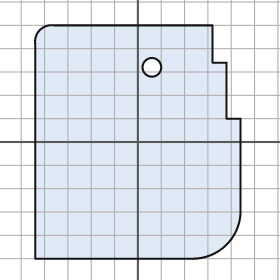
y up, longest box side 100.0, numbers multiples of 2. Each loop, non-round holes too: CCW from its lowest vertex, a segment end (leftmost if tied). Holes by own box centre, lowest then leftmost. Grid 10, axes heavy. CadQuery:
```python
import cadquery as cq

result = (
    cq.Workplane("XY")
    .moveTo(-44.0, -50.0)
    .lineTo(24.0, -50.0)
    .threePointArc((38.0, -44.0), (44.0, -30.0))
    .lineTo(44.0, 10.0)
    .lineTo(38.0, 10.0)
    .lineTo(38.0, 34.0)
    .lineTo(32.0, 34.0)
    .lineTo(32.0, 50.0)
    .lineTo(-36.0, 50.0)
    .threePointArc((-42.0, 48.0), (-44.0, 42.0))
    .close()
    .moveTo(6.0, 32.0)
    .circle(4.0)
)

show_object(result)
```